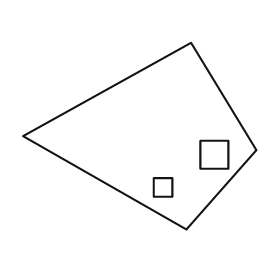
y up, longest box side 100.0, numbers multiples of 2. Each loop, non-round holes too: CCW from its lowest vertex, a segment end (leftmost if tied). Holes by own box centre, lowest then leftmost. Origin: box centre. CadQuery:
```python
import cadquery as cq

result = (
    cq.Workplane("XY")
    .moveTo(20.0, -40.0)
    .lineTo(50.0, -6.0)
    .lineTo(22.0, 40.0)
    .lineTo(-50.0, 0.0)
    .close()
    .moveTo(6.0, -26.0)
    .lineTo(14.0, -26.0)
    .lineTo(14.0, -18.0)
    .lineTo(6.0, -18.0)
    .close()
    .moveTo(26.0, -14.0)
    .lineTo(38.0, -14.0)
    .lineTo(38.0, -2.0)
    .lineTo(26.0, -2.0)
    .close()
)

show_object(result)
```